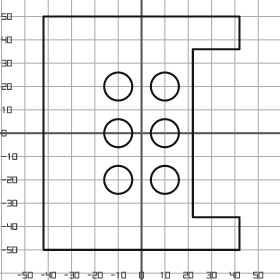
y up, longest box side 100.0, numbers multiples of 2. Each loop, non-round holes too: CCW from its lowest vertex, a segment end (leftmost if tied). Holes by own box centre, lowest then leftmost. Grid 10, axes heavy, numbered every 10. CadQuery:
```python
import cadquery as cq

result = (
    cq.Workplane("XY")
    .moveTo(-42.0, -50.0)
    .lineTo(42.0, -50.0)
    .lineTo(42.0, -36.0)
    .lineTo(22.0, -36.0)
    .lineTo(22.0, 36.0)
    .lineTo(42.0, 36.0)
    .lineTo(42.0, 50.0)
    .lineTo(-42.0, 50.0)
    .close()
    .moveTo(-10.0, -20.0)
    .circle(6.0)
    .moveTo(10.0, -20.0)
    .circle(6.0)
    .moveTo(-10.0, 0.0)
    .circle(6.0)
    .moveTo(10.0, 0.0)
    .circle(6.0)
    .moveTo(-10.0, 20.0)
    .circle(6.0)
    .moveTo(10.0, 20.0)
    .circle(6.0)
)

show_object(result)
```